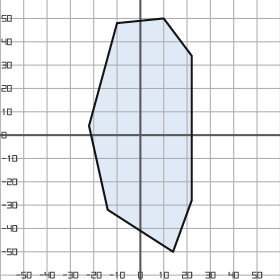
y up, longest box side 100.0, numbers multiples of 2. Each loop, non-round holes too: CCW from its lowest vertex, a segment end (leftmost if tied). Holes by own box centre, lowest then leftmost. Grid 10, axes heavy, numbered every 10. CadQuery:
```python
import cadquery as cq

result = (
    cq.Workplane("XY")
    .moveTo(14.0, -50.0)
    .lineTo(22.0, -28.0)
    .lineTo(22.0, 34.0)
    .lineTo(10.0, 50.0)
    .lineTo(-10.0, 48.0)
    .lineTo(-22.0, 4.0)
    .lineTo(-14.0, -32.0)
    .close()
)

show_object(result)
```